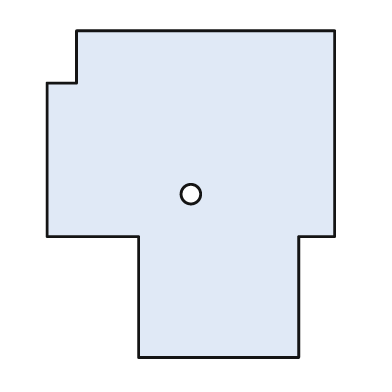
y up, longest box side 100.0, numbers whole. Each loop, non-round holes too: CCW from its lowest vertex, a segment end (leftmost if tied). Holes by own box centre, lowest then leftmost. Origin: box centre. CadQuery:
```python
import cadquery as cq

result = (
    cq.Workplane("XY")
    .moveTo(-16.0, -50.0)
    .lineTo(33.0, -50.0)
    .lineTo(33.0, -13.0)
    .lineTo(44.0, -13.0)
    .lineTo(44.0, 50.0)
    .lineTo(-35.0, 50.0)
    .lineTo(-35.0, 34.0)
    .lineTo(-44.0, 34.0)
    .lineTo(-44.0, -13.0)
    .lineTo(-16.0, -13.0)
    .close()
    .moveTo(0.0, 0.0)
    .circle(3.0)
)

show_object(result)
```